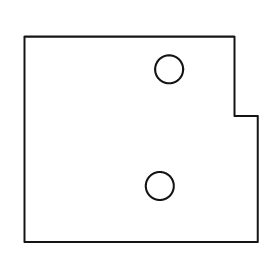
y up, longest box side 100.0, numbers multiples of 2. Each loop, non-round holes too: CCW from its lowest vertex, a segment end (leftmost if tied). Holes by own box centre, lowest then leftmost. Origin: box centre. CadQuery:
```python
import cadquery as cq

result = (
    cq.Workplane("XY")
    .moveTo(-50.0, -44.0)
    .lineTo(50.0, -44.0)
    .lineTo(50.0, 10.0)
    .lineTo(40.0, 10.0)
    .lineTo(40.0, 44.0)
    .lineTo(-50.0, 44.0)
    .close()
    .moveTo(8.0, -20.0)
    .circle(6.0)
    .moveTo(12.0, 30.0)
    .circle(6.0)
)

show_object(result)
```